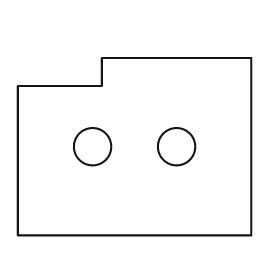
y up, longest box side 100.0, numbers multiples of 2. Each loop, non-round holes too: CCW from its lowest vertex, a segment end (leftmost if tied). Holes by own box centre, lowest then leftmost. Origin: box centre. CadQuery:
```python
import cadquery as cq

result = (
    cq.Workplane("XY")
    .moveTo(-50.0, -38.0)
    .lineTo(50.0, -38.0)
    .lineTo(50.0, 38.0)
    .lineTo(-14.0, 38.0)
    .lineTo(-14.0, 26.0)
    .lineTo(-50.0, 26.0)
    .close()
    .moveTo(-18.0, 0.0)
    .circle(8.0)
    .moveTo(18.0, 0.0)
    .circle(8.0)
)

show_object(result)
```